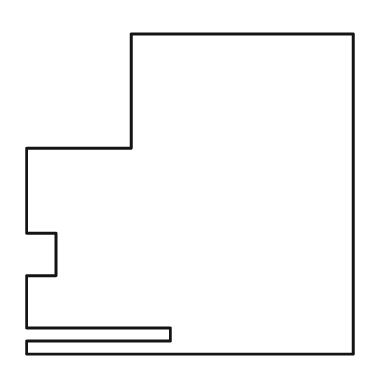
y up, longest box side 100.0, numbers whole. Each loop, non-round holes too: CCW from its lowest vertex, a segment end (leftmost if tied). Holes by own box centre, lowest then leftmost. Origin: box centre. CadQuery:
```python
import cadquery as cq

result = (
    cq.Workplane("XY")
    .moveTo(-50.0, -49.0)
    .lineTo(50.0, -49.0)
    .lineTo(50.0, 49.0)
    .lineTo(-18.0, 49.0)
    .lineTo(-18.0, 14.0)
    .lineTo(-50.0, 14.0)
    .lineTo(-50.0, -12.0)
    .lineTo(-41.0, -12.0)
    .lineTo(-41.0, -25.0)
    .lineTo(-50.0, -25.0)
    .lineTo(-50.0, -41.0)
    .lineTo(-6.0, -41.0)
    .lineTo(-6.0, -45.0)
    .lineTo(-50.0, -45.0)
    .close()
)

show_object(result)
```